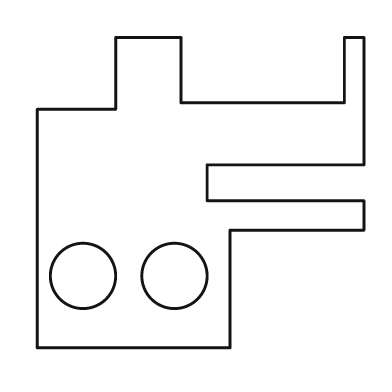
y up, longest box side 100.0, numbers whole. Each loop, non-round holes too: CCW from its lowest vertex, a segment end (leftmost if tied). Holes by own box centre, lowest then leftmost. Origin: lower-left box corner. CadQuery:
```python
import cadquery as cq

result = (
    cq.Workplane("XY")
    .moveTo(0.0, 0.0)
    .lineTo(59.0, 0.0)
    .lineTo(59.0, 36.0)
    .lineTo(100.0, 36.0)
    .lineTo(100.0, 45.0)
    .lineTo(52.0, 45.0)
    .lineTo(52.0, 56.0)
    .lineTo(100.0, 56.0)
    .lineTo(100.0, 95.0)
    .lineTo(94.0, 95.0)
    .lineTo(94.0, 75.0)
    .lineTo(44.0, 75.0)
    .lineTo(44.0, 95.0)
    .lineTo(24.0, 95.0)
    .lineTo(24.0, 73.0)
    .lineTo(0.0, 73.0)
    .close()
    .moveTo(14.0, 22.0)
    .circle(10.0)
    .moveTo(42.0, 22.0)
    .circle(10.0)
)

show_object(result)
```